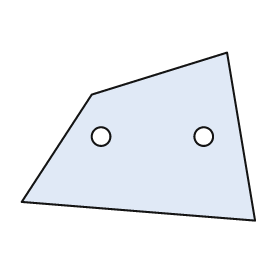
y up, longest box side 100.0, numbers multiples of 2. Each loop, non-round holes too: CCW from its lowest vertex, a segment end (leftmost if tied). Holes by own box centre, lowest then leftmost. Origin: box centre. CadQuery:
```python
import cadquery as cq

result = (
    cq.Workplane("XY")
    .moveTo(50.0, -36.0)
    .lineTo(38.0, 36.0)
    .lineTo(-20.0, 18.0)
    .lineTo(-50.0, -28.0)
    .close()
    .moveTo(-16.0, 0.0)
    .circle(4.0)
    .moveTo(28.0, 0.0)
    .circle(4.0)
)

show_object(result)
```